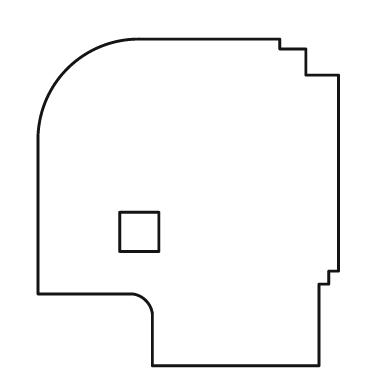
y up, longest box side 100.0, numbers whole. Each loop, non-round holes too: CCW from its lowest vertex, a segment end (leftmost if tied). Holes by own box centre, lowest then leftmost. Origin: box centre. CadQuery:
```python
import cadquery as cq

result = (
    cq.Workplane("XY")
    .moveTo(-11.0, -50.0)
    .lineTo(40.0, -50.0)
    .lineTo(40.0, -25.0)
    .lineTo(43.0, -25.0)
    .lineTo(43.0, -21.0)
    .lineTo(46.0, -21.0)
    .lineTo(46.0, 39.0)
    .lineTo(36.0, 39.0)
    .lineTo(36.0, 47.0)
    .lineTo(28.0, 47.0)
    .lineTo(28.0, 50.0)
    .lineTo(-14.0, 50.0)
    .threePointArc((-37.0, 41.0), (-46.0, 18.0))
    .lineTo(-46.0, -28.0)
    .lineTo(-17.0, -28.0)
    .threePointArc((-13.0, -30.0), (-11.0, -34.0))
    .close()
    .moveTo(-21.0, -15.0)
    .lineTo(-9.0, -15.0)
    .lineTo(-9.0, -3.0)
    .lineTo(-21.0, -3.0)
    .close()
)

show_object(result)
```